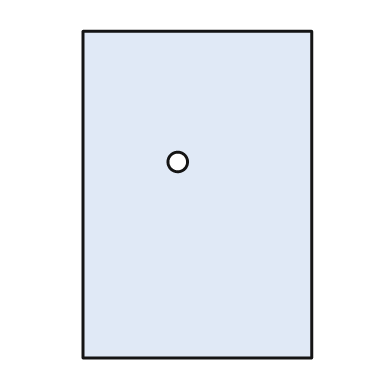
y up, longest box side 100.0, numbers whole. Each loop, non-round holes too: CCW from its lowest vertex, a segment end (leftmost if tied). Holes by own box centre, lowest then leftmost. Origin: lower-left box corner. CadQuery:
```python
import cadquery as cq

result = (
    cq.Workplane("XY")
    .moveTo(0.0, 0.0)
    .lineTo(70.0, 0.0)
    .lineTo(70.0, 100.0)
    .lineTo(0.0, 100.0)
    .close()
    .moveTo(29.0, 60.0)
    .circle(3.0)
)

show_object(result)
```